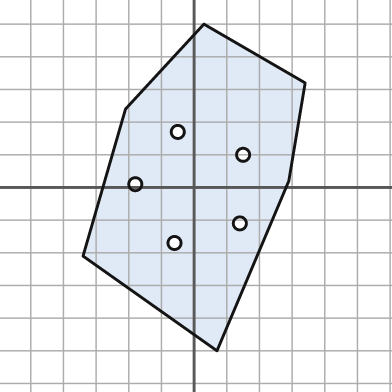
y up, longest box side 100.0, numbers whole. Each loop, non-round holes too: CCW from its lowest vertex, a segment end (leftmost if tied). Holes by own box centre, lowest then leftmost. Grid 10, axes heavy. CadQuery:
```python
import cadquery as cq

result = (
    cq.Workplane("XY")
    .moveTo(7.0, -50.0)
    .lineTo(29.0, 2.0)
    .lineTo(34.0, 32.0)
    .lineTo(3.0, 50.0)
    .lineTo(-21.0, 24.0)
    .lineTo(-34.0, -21.0)
    .close()
    .moveTo(-6.0, -17.0)
    .circle(2.0)
    .moveTo(14.0, -11.0)
    .circle(2.0)
    .moveTo(-18.0, 1.0)
    .circle(2.0)
    .moveTo(15.0, 10.0)
    .circle(2.0)
    .moveTo(-5.0, 17.0)
    .circle(2.0)
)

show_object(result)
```